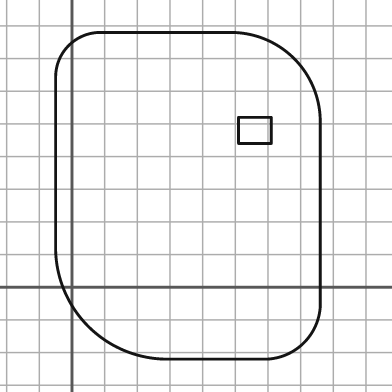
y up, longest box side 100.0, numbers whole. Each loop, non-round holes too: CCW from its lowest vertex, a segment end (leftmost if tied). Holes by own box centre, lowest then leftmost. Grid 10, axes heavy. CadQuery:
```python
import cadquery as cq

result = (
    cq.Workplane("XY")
    .moveTo(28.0, -22.0)
    .lineTo(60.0, -22.0)
    .threePointArc((71.0, -17.0), (76.0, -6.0))
    .lineTo(76.0, 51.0)
    .threePointArc((68.0, 70.0), (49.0, 78.0))
    .lineTo(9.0, 78.0)
    .threePointArc((-1.0, 74.0), (-5.0, 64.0))
    .lineTo(-5.0, 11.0)
    .threePointArc((5.0, -12.0), (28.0, -22.0))
    .close()
    .moveTo(51.0, 44.0)
    .lineTo(61.0, 44.0)
    .lineTo(61.0, 52.0)
    .lineTo(51.0, 52.0)
    .close()
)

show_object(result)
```